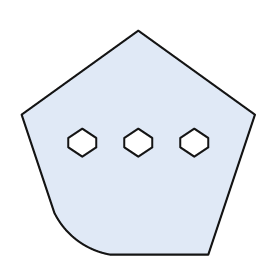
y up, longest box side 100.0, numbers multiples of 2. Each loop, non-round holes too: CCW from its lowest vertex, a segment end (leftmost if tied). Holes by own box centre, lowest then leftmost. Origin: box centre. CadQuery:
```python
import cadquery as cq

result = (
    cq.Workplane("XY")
    .moveTo(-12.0, -48.0)
    .lineTo(30.0, -48.0)
    .lineTo(50.0, 12.0)
    .lineTo(0.0, 48.0)
    .lineTo(-50.0, 12.0)
    .lineTo(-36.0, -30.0)
    .threePointArc((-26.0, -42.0), (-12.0, -48.0))
    .close()
    .moveTo(-24.0, -6.0)
    .lineTo(-18.0, -2.0)
    .lineTo(-18.0, 2.0)
    .lineTo(-24.0, 6.0)
    .lineTo(-30.0, 2.0)
    .lineTo(-30.0, -2.0)
    .close()
    .moveTo(0.0, -6.0)
    .lineTo(6.0, -2.0)
    .lineTo(6.0, 2.0)
    .lineTo(0.0, 6.0)
    .lineTo(-6.0, 2.0)
    .lineTo(-6.0, -2.0)
    .close()
    .moveTo(24.0, -6.0)
    .lineTo(30.0, -2.0)
    .lineTo(30.0, 2.0)
    .lineTo(24.0, 6.0)
    .lineTo(18.0, 2.0)
    .lineTo(18.0, -2.0)
    .close()
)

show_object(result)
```